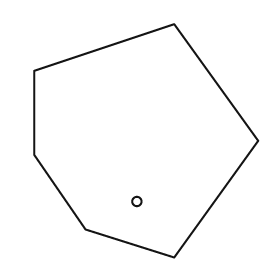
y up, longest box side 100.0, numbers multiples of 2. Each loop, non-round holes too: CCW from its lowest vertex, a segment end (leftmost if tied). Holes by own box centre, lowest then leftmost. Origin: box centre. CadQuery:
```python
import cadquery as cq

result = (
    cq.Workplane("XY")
    .moveTo(12.0, -50.0)
    .lineTo(48.0, 0.0)
    .lineTo(12.0, 50.0)
    .lineTo(-48.0, 30.0)
    .lineTo(-48.0, -6.0)
    .lineTo(-26.0, -38.0)
    .close()
    .moveTo(-4.0, -26.0)
    .circle(2.0)
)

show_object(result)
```